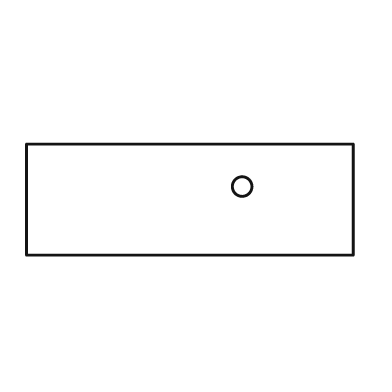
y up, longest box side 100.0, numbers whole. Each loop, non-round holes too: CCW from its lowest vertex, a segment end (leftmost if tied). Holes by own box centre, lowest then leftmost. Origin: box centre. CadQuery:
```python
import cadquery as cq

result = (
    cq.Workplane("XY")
    .moveTo(-50.0, -17.0)
    .lineTo(50.0, -17.0)
    .lineTo(50.0, 17.0)
    .lineTo(-50.0, 17.0)
    .close()
    .moveTo(16.0, 4.0)
    .circle(3.0)
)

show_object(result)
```